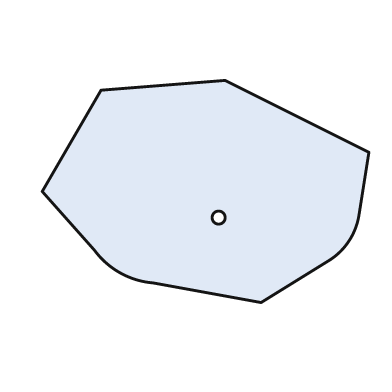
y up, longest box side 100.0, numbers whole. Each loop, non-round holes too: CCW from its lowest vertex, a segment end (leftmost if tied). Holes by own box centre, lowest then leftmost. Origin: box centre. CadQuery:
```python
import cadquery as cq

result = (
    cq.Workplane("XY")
    .moveTo(17.0, -34.0)
    .lineTo(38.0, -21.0)
    .threePointArc((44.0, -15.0), (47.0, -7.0))
    .lineTo(50.0, 12.0)
    .lineTo(6.0, 34.0)
    .lineTo(-32.0, 31.0)
    .lineTo(-50.0, 0.0)
    .lineTo(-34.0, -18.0)
    .threePointArc((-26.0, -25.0), (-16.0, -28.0))
    .close()
    .moveTo(4.0, -8.0)
    .circle(2.0)
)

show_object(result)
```